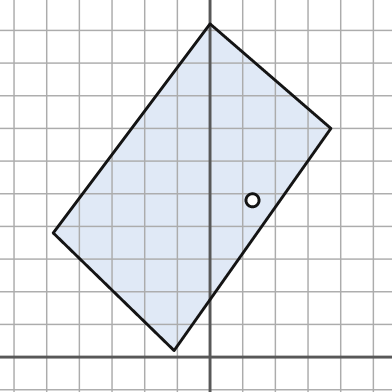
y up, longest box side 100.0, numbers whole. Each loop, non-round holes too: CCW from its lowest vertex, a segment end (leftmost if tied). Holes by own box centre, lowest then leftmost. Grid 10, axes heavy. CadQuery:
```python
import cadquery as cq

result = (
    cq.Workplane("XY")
    .moveTo(-11.0, 2.0)
    .lineTo(37.0, 70.0)
    .lineTo(0.0, 102.0)
    .lineTo(-48.0, 38.0)
    .close()
    .moveTo(13.0, 48.0)
    .circle(2.0)
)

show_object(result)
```